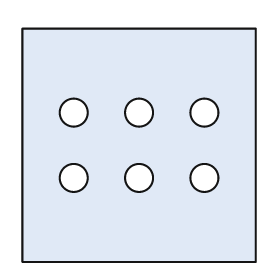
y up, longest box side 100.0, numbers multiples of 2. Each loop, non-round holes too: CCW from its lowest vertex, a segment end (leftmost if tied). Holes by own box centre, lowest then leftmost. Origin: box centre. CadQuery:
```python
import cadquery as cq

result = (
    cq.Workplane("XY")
    .moveTo(-50.0, -50.0)
    .lineTo(50.0, -50.0)
    .lineTo(50.0, 50.0)
    .lineTo(-50.0, 50.0)
    .close()
    .moveTo(-28.0, -14.0)
    .circle(6.0)
    .moveTo(0.0, -14.0)
    .circle(6.0)
    .moveTo(28.0, -14.0)
    .circle(6.0)
    .moveTo(-28.0, 14.0)
    .circle(6.0)
    .moveTo(0.0, 14.0)
    .circle(6.0)
    .moveTo(28.0, 14.0)
    .circle(6.0)
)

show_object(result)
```